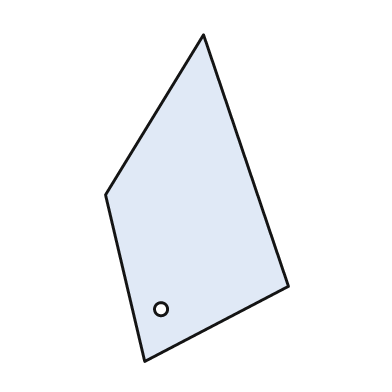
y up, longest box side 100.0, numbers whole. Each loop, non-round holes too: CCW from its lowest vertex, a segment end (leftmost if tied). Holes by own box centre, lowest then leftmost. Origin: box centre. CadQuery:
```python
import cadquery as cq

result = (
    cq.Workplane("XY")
    .moveTo(-16.0, -50.0)
    .lineTo(28.0, -27.0)
    .lineTo(2.0, 50.0)
    .lineTo(-28.0, 1.0)
    .close()
    .moveTo(-11.0, -34.0)
    .circle(2.0)
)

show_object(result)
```